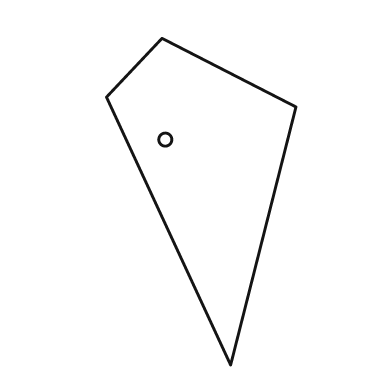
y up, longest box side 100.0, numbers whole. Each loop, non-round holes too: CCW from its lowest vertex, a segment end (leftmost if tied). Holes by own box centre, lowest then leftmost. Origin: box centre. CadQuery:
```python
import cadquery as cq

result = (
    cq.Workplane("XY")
    .moveTo(9.0, -50.0)
    .lineTo(29.0, 29.0)
    .lineTo(-12.0, 50.0)
    .lineTo(-29.0, 32.0)
    .close()
    .moveTo(-11.0, 19.0)
    .circle(2.0)
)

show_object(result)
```